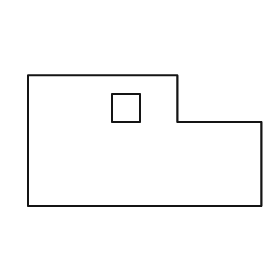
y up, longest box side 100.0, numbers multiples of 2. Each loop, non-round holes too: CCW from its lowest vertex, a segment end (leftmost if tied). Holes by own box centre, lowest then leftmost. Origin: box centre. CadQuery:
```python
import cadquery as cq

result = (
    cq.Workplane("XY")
    .moveTo(-50.0, -28.0)
    .lineTo(50.0, -28.0)
    .lineTo(50.0, 8.0)
    .lineTo(14.0, 8.0)
    .lineTo(14.0, 28.0)
    .lineTo(-50.0, 28.0)
    .close()
    .moveTo(-14.0, 8.0)
    .lineTo(-2.0, 8.0)
    .lineTo(-2.0, 20.0)
    .lineTo(-14.0, 20.0)
    .close()
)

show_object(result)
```